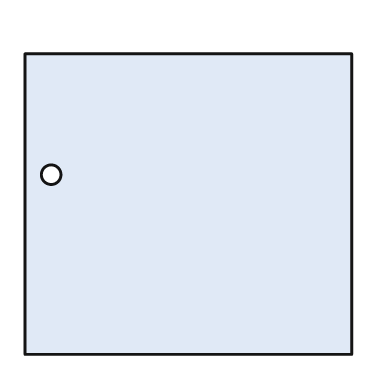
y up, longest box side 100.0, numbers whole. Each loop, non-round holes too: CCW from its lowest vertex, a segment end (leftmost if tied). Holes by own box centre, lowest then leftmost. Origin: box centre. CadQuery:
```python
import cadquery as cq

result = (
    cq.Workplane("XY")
    .moveTo(-50.0, -46.0)
    .lineTo(50.0, -46.0)
    .lineTo(50.0, 46.0)
    .lineTo(-50.0, 46.0)
    .close()
    .moveTo(-42.0, 9.0)
    .circle(3.0)
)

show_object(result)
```